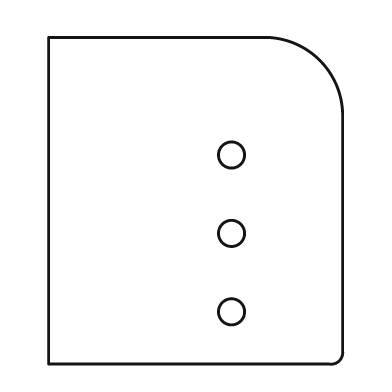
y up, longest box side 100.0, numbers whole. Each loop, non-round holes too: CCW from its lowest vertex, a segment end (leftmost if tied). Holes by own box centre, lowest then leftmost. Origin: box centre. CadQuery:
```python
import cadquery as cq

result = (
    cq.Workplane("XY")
    .moveTo(-45.0, -50.0)
    .lineTo(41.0, -50.0)
    .threePointArc((44.0, -49.0), (45.0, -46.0))
    .lineTo(45.0, 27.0)
    .threePointArc((38.0, 43.0), (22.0, 50.0))
    .lineTo(-45.0, 50.0)
    .close()
    .moveTo(11.0, -34.0)
    .circle(4.0)
    .moveTo(11.0, -10.0)
    .circle(4.0)
    .moveTo(11.0, 14.0)
    .circle(4.0)
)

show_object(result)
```